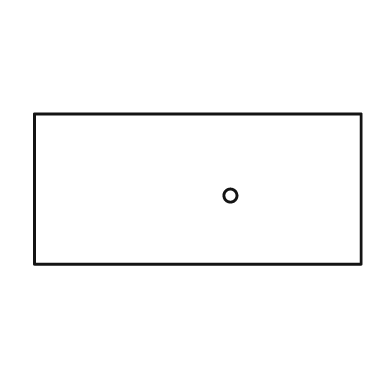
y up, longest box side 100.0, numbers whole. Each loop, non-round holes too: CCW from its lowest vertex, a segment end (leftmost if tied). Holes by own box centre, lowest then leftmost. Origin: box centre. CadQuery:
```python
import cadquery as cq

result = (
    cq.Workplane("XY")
    .moveTo(-50.0, -23.0)
    .lineTo(50.0, -23.0)
    .lineTo(50.0, 23.0)
    .lineTo(-50.0, 23.0)
    .close()
    .moveTo(10.0, -2.0)
    .circle(2.0)
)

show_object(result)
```